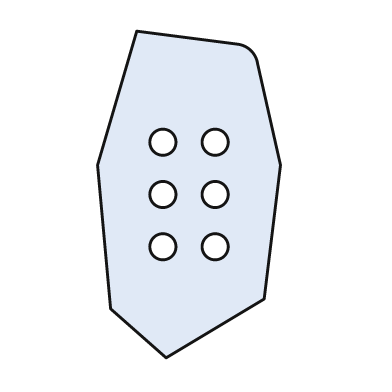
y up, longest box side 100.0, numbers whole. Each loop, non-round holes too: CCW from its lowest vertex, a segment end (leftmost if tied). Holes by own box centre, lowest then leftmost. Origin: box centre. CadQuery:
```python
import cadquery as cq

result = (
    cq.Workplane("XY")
    .moveTo(-7.0, -50.0)
    .lineTo(23.0, -32.0)
    .lineTo(28.0, 9.0)
    .lineTo(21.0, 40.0)
    .threePointArc((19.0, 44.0), (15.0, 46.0))
    .lineTo(-16.0, 50.0)
    .lineTo(-28.0, 9.0)
    .lineTo(-24.0, -35.0)
    .close()
    .moveTo(-8.0, -16.0)
    .circle(4.0)
    .moveTo(8.0, -16.0)
    .circle(4.0)
    .moveTo(-8.0, 0.0)
    .circle(4.0)
    .moveTo(8.0, 0.0)
    .circle(4.0)
    .moveTo(-8.0, 16.0)
    .circle(4.0)
    .moveTo(8.0, 16.0)
    .circle(4.0)
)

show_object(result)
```